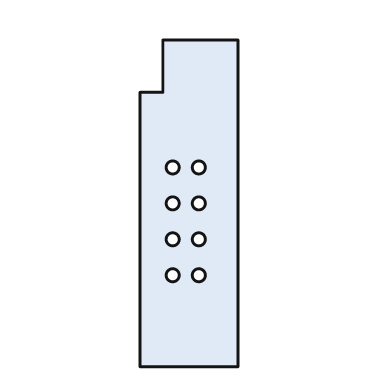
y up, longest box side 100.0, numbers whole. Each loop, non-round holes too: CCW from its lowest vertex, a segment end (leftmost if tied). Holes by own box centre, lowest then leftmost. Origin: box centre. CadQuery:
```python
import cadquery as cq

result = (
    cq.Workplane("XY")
    .moveTo(-15.0, -50.0)
    .lineTo(15.0, -50.0)
    .lineTo(15.0, 50.0)
    .lineTo(-8.0, 50.0)
    .lineTo(-8.0, 34.0)
    .lineTo(-15.0, 34.0)
    .close()
    .moveTo(-5.0, -22.0)
    .circle(2.0)
    .moveTo(3.0, -22.0)
    .circle(2.0)
    .moveTo(-5.0, -11.0)
    .circle(2.0)
    .moveTo(3.0, -11.0)
    .circle(2.0)
    .moveTo(-5.0, 0.0)
    .circle(2.0)
    .moveTo(3.0, 0.0)
    .circle(2.0)
    .moveTo(-5.0, 11.0)
    .circle(2.0)
    .moveTo(3.0, 11.0)
    .circle(2.0)
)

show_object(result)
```